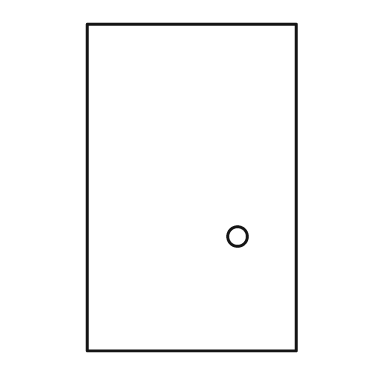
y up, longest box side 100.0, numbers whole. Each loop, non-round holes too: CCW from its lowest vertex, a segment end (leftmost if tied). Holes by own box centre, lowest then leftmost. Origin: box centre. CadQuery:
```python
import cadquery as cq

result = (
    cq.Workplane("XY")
    .moveTo(-32.0, -50.0)
    .lineTo(32.0, -50.0)
    .lineTo(32.0, 50.0)
    .lineTo(-32.0, 50.0)
    .close()
    .moveTo(14.0, -15.0)
    .circle(3.0)
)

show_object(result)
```